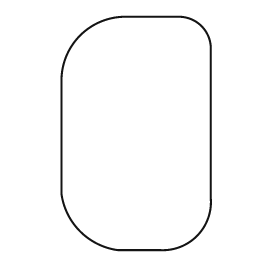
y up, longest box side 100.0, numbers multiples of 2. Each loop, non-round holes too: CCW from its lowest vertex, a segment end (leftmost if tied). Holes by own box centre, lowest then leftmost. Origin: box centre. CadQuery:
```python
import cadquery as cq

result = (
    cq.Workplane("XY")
    .moveTo(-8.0, -50.0)
    .lineTo(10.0, -50.0)
    .threePointArc((26.0, -44.0), (32.0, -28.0))
    .lineTo(32.0, 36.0)
    .threePointArc((28.0, 46.0), (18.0, 50.0))
    .lineTo(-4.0, 50.0)
    .threePointArc((-24.0, 42.0), (-32.0, 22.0))
    .lineTo(-32.0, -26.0)
    .threePointArc((-24.0, -42.0), (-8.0, -50.0))
    .close()
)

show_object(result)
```